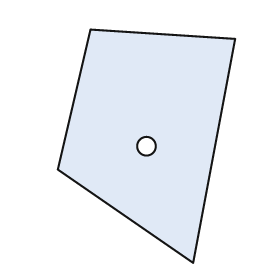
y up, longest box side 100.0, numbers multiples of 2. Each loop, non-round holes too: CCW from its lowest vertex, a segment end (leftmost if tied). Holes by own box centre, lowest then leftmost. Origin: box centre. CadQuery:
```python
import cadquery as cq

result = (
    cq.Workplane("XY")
    .moveTo(20.0, -50.0)
    .lineTo(38.0, 46.0)
    .lineTo(-24.0, 50.0)
    .lineTo(-38.0, -10.0)
    .close()
    .moveTo(0.0, 0.0)
    .circle(4.0)
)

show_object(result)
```